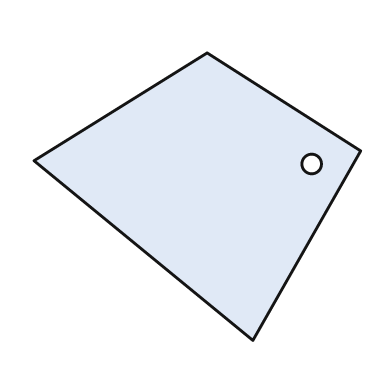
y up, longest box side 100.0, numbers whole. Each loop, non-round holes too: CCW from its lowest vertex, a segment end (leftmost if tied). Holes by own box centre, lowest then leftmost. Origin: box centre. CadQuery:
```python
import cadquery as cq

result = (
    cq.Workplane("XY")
    .moveTo(17.0, -44.0)
    .lineTo(50.0, 14.0)
    .lineTo(3.0, 44.0)
    .lineTo(-50.0, 11.0)
    .close()
    .moveTo(35.0, 10.0)
    .circle(3.0)
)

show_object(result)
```